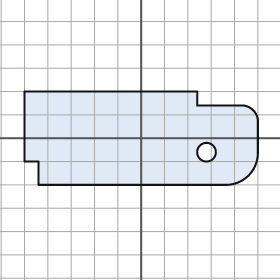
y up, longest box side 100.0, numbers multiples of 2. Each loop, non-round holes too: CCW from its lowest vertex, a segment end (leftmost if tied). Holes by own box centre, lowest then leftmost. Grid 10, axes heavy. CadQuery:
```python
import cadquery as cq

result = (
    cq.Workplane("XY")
    .moveTo(-44.0, -20.0)
    .lineTo(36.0, -20.0)
    .threePointArc((46.0, -16.0), (50.0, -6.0))
    .lineTo(50.0, 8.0)
    .threePointArc((48.0, 12.0), (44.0, 14.0))
    .lineTo(24.0, 14.0)
    .lineTo(24.0, 20.0)
    .lineTo(-50.0, 20.0)
    .lineTo(-50.0, -10.0)
    .lineTo(-44.0, -10.0)
    .close()
    .moveTo(28.0, -6.0)
    .circle(4.0)
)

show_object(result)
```